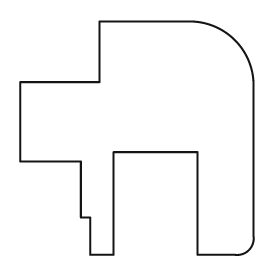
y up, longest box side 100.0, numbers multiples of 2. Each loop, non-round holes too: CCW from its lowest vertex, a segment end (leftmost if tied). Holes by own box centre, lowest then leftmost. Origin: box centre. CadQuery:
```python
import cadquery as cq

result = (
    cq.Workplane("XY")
    .moveTo(-20.0, -50.0)
    .lineTo(-10.0, -50.0)
    .lineTo(-10.0, -6.0)
    .lineTo(26.0, -6.0)
    .lineTo(26.0, -50.0)
    .lineTo(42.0, -50.0)
    .threePointArc((48.0, -48.0), (50.0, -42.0))
    .lineTo(50.0, 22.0)
    .threePointArc((42.0, 42.0), (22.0, 50.0))
    .lineTo(-16.0, 50.0)
    .lineTo(-16.0, 24.0)
    .lineTo(-50.0, 24.0)
    .lineTo(-50.0, -10.0)
    .lineTo(-24.0, -10.0)
    .lineTo(-24.0, -34.0)
    .lineTo(-20.0, -34.0)
    .close()
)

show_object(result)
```